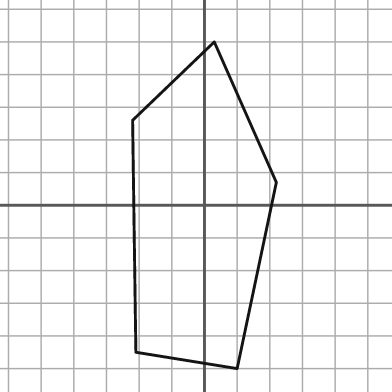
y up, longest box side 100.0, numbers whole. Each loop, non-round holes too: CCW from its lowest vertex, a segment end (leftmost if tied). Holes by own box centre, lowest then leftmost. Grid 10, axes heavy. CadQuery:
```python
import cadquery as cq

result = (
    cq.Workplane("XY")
    .moveTo(10.0, -50.0)
    .lineTo(22.0, 7.0)
    .lineTo(3.0, 50.0)
    .lineTo(-22.0, 26.0)
    .lineTo(-21.0, -45.0)
    .close()
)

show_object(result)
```